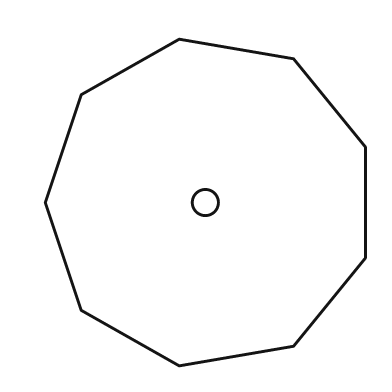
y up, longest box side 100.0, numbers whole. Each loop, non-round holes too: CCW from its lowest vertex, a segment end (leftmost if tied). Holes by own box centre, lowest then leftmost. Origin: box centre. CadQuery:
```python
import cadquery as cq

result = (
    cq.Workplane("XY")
    .moveTo(-8.0, -50.0)
    .lineTo(27.0, -44.0)
    .lineTo(49.0, -17.0)
    .lineTo(49.0, 17.0)
    .lineTo(27.0, 44.0)
    .lineTo(-8.0, 50.0)
    .lineTo(-38.0, 33.0)
    .lineTo(-49.0, 0.0)
    .lineTo(-38.0, -33.0)
    .close()
    .moveTo(0.0, 0.0)
    .circle(4.0)
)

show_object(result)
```